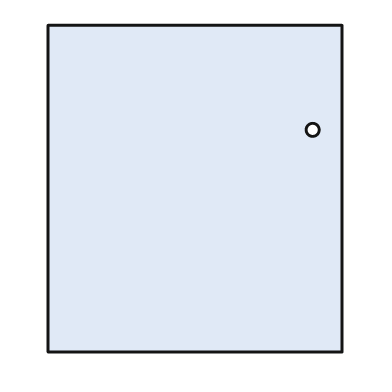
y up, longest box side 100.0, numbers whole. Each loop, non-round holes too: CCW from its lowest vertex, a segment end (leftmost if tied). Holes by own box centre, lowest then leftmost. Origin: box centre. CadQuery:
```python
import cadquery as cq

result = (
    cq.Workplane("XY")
    .moveTo(-45.0, -50.0)
    .lineTo(45.0, -50.0)
    .lineTo(45.0, 50.0)
    .lineTo(-45.0, 50.0)
    .close()
    .moveTo(36.0, 18.0)
    .circle(2.0)
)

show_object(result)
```